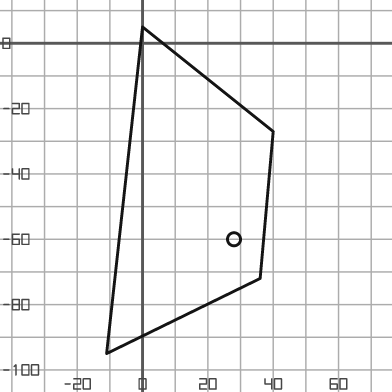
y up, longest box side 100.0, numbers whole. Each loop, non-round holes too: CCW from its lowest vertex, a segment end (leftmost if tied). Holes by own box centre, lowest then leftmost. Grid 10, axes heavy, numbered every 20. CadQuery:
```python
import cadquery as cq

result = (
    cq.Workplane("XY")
    .moveTo(-11.0, -95.0)
    .lineTo(36.0, -72.0)
    .lineTo(40.0, -27.0)
    .lineTo(0.0, 5.0)
    .close()
    .moveTo(28.0, -60.0)
    .circle(2.0)
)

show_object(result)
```